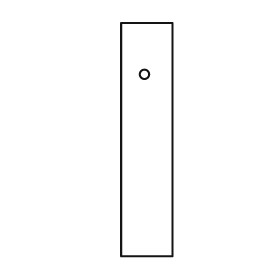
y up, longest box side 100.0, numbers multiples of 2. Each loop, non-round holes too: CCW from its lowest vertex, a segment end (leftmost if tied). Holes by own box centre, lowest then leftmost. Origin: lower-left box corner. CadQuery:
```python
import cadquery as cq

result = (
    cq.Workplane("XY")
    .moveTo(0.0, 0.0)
    .lineTo(22.0, 0.0)
    .lineTo(22.0, 100.0)
    .lineTo(0.0, 100.0)
    .close()
    .moveTo(10.0, 78.0)
    .circle(2.0)
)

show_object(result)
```